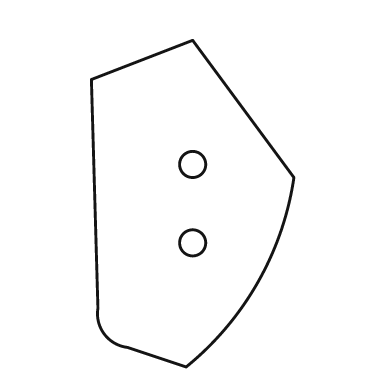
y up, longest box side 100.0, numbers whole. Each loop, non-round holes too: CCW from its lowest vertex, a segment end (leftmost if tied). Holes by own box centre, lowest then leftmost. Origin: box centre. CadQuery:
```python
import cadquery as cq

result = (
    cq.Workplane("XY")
    .moveTo(-2.0, -50.0)
    .threePointArc((20.0, -24.0), (31.0, 8.0))
    .lineTo(0.0, 50.0)
    .lineTo(-31.0, 38.0)
    .lineTo(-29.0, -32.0)
    .threePointArc((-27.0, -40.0), (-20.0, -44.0))
    .close()
    .moveTo(0.0, -12.0)
    .circle(4.0)
    .moveTo(0.0, 12.0)
    .circle(4.0)
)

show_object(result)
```